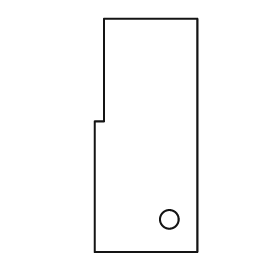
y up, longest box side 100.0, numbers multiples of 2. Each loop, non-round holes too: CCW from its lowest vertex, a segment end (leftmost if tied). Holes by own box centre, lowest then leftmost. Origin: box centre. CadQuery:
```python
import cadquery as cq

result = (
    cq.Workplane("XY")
    .moveTo(-22.0, -50.0)
    .lineTo(22.0, -50.0)
    .lineTo(22.0, 50.0)
    .lineTo(-18.0, 50.0)
    .lineTo(-18.0, 6.0)
    .lineTo(-22.0, 6.0)
    .close()
    .moveTo(10.0, -36.0)
    .circle(4.0)
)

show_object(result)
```